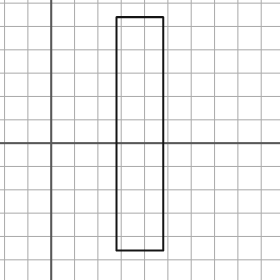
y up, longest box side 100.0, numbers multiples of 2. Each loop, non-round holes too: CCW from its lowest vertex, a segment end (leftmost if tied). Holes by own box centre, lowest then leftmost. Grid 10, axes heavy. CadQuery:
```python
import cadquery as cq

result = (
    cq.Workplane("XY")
    .moveTo(28.0, -46.0)
    .lineTo(48.0, -46.0)
    .lineTo(48.0, 54.0)
    .lineTo(28.0, 54.0)
    .close()
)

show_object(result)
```